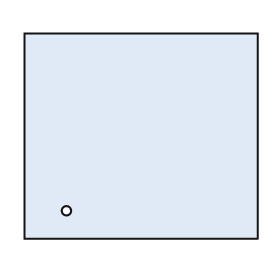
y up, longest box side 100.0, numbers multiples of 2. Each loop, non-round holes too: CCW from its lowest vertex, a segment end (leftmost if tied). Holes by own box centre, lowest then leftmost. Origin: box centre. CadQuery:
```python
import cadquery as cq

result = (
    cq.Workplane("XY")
    .moveTo(-50.0, -44.0)
    .lineTo(50.0, -44.0)
    .lineTo(50.0, 44.0)
    .lineTo(-50.0, 44.0)
    .close()
    .moveTo(-32.0, -32.0)
    .circle(2.0)
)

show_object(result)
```